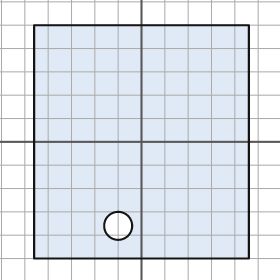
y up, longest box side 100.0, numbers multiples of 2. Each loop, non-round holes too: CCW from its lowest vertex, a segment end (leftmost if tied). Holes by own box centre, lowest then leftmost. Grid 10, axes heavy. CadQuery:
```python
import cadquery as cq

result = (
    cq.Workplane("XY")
    .moveTo(-46.0, -50.0)
    .lineTo(46.0, -50.0)
    .lineTo(46.0, 50.0)
    .lineTo(-46.0, 50.0)
    .close()
    .moveTo(-10.0, -36.0)
    .circle(6.0)
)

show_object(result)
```